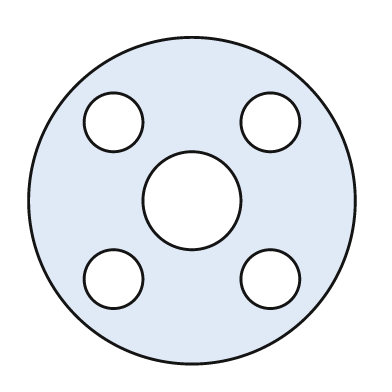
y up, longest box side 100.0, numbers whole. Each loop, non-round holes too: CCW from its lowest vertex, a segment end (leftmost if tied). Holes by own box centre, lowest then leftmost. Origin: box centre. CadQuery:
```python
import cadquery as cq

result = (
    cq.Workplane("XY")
    .moveTo(0.0, 0.0)
    .circle(50.0)
    .moveTo(-24.0, -24.0)
    .circle(9.0)
    .moveTo(24.0, -24.0)
    .circle(9.0)
    .moveTo(0.0, 0.0)
    .circle(15.0)
    .moveTo(-24.0, 24.0)
    .circle(9.0)
    .moveTo(24.0, 24.0)
    .circle(9.0)
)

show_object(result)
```